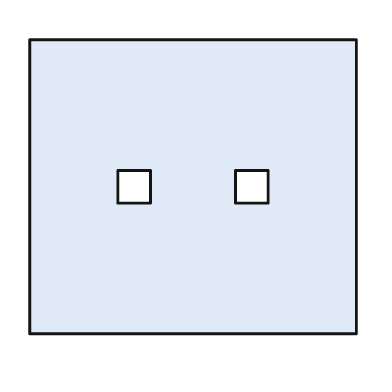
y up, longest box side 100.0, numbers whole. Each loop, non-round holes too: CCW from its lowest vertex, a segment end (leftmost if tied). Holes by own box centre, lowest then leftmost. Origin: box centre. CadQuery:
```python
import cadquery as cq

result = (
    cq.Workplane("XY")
    .moveTo(-50.0, -45.0)
    .lineTo(50.0, -45.0)
    .lineTo(50.0, 45.0)
    .lineTo(-50.0, 45.0)
    .close()
    .moveTo(-23.0, -5.0)
    .lineTo(-13.0, -5.0)
    .lineTo(-13.0, 5.0)
    .lineTo(-23.0, 5.0)
    .close()
    .moveTo(13.0, -5.0)
    .lineTo(23.0, -5.0)
    .lineTo(23.0, 5.0)
    .lineTo(13.0, 5.0)
    .close()
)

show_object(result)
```